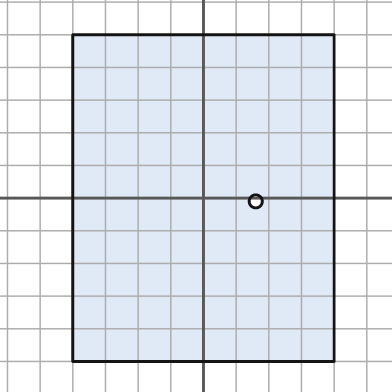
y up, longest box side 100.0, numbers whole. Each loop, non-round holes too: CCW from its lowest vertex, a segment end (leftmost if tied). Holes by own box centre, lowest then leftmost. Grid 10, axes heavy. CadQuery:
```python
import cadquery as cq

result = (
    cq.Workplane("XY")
    .moveTo(-40.0, -50.0)
    .lineTo(40.0, -50.0)
    .lineTo(40.0, 50.0)
    .lineTo(-40.0, 50.0)
    .close()
    .moveTo(16.0, -1.0)
    .circle(2.0)
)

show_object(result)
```